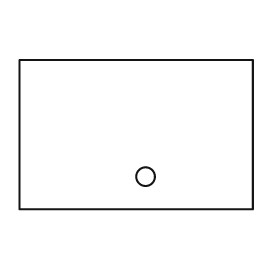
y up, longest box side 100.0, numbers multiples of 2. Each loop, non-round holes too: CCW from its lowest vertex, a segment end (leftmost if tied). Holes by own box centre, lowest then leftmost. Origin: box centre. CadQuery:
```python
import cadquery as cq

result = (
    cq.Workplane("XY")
    .moveTo(-50.0, -32.0)
    .lineTo(50.0, -32.0)
    .lineTo(50.0, 32.0)
    .lineTo(-50.0, 32.0)
    .close()
    .moveTo(4.0, -18.0)
    .circle(4.0)
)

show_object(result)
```